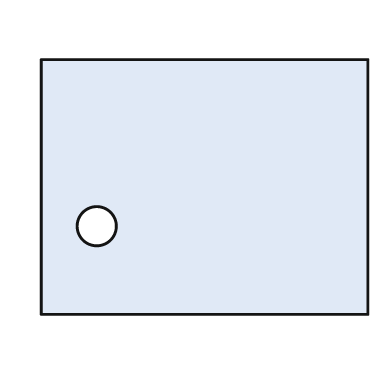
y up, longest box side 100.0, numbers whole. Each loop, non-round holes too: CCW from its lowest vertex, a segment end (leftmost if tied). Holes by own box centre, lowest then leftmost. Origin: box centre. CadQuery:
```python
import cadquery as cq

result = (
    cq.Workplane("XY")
    .moveTo(-50.0, -39.0)
    .lineTo(50.0, -39.0)
    .lineTo(50.0, 39.0)
    .lineTo(-50.0, 39.0)
    .close()
    .moveTo(-33.0, -12.0)
    .circle(6.0)
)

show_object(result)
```